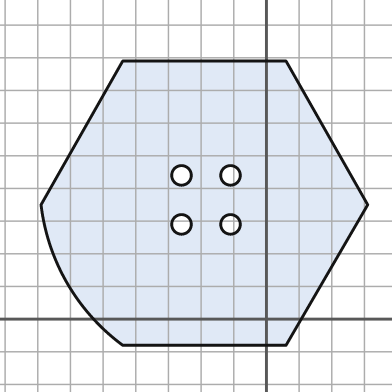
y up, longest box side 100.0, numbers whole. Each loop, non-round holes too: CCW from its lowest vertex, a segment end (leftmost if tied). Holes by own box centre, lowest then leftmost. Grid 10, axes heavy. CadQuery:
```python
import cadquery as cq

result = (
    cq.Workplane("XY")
    .moveTo(-44.0, -8.0)
    .lineTo(6.0, -8.0)
    .lineTo(31.0, 35.0)
    .lineTo(6.0, 79.0)
    .lineTo(-44.0, 79.0)
    .lineTo(-69.0, 35.0)
    .threePointArc((-61.0, 11.0), (-44.0, -8.0))
    .close()
    .moveTo(-26.0, 29.0)
    .circle(3.0)
    .moveTo(-11.0, 29.0)
    .circle(3.0)
    .moveTo(-26.0, 44.0)
    .circle(3.0)
    .moveTo(-11.0, 44.0)
    .circle(3.0)
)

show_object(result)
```